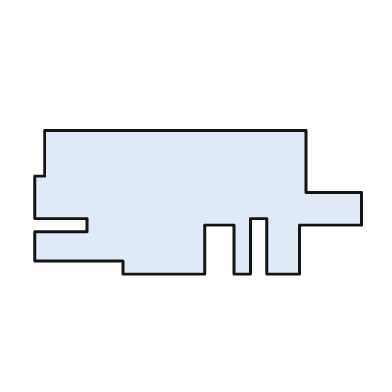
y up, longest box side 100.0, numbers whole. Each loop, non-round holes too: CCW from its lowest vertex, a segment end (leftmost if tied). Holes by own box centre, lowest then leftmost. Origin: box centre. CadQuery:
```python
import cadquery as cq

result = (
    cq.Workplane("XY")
    .moveTo(-23.0, -22.0)
    .lineTo(2.0, -22.0)
    .lineTo(2.0, -7.0)
    .lineTo(11.0, -7.0)
    .lineTo(11.0, -22.0)
    .lineTo(16.0, -22.0)
    .lineTo(16.0, -5.0)
    .lineTo(21.0, -5.0)
    .lineTo(21.0, -22.0)
    .lineTo(31.0, -22.0)
    .lineTo(31.0, -7.0)
    .lineTo(50.0, -7.0)
    .lineTo(50.0, 3.0)
    .lineTo(33.0, 3.0)
    .lineTo(33.0, 22.0)
    .lineTo(-47.0, 22.0)
    .lineTo(-47.0, 8.0)
    .lineTo(-50.0, 8.0)
    .lineTo(-50.0, -5.0)
    .lineTo(-34.0, -5.0)
    .lineTo(-34.0, -9.0)
    .lineTo(-50.0, -9.0)
    .lineTo(-50.0, -18.0)
    .lineTo(-23.0, -18.0)
    .close()
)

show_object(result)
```